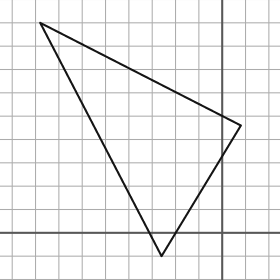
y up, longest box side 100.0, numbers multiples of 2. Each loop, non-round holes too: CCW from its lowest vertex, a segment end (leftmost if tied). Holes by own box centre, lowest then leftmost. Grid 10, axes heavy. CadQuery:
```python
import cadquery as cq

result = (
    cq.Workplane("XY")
    .moveTo(-26.0, -10.0)
    .lineTo(8.0, 46.0)
    .lineTo(-78.0, 90.0)
    .close()
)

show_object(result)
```